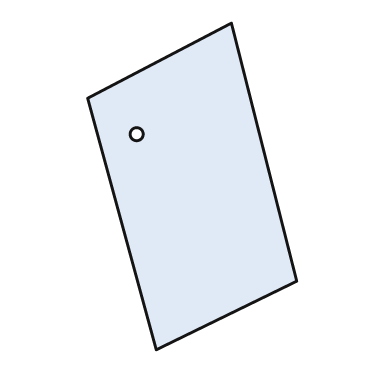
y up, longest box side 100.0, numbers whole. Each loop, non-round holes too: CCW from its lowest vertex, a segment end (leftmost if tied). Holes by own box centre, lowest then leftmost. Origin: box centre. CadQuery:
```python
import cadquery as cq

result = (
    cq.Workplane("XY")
    .moveTo(-11.0, -50.0)
    .lineTo(32.0, -29.0)
    .lineTo(12.0, 50.0)
    .lineTo(-32.0, 27.0)
    .close()
    .moveTo(-17.0, 16.0)
    .circle(2.0)
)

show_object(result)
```